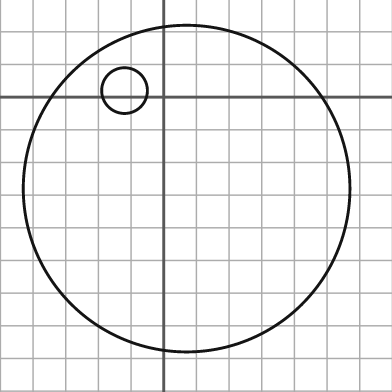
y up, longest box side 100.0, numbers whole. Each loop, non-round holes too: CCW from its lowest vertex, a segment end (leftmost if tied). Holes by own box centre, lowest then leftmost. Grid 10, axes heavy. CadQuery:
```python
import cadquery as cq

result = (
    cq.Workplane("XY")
    .moveTo(7.0, -28.0)
    .circle(50.0)
    .moveTo(-12.0, 2.0)
    .circle(7.0)
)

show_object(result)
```